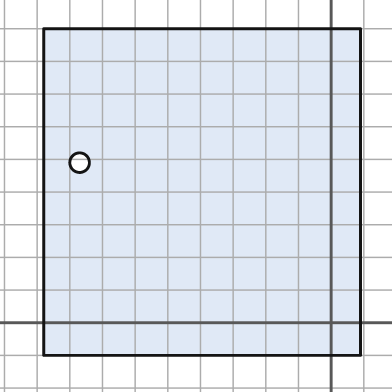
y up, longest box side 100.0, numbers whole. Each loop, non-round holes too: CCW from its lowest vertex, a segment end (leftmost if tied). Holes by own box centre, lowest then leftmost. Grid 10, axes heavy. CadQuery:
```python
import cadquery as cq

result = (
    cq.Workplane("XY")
    .moveTo(-88.0, -10.0)
    .lineTo(9.0, -10.0)
    .lineTo(9.0, 90.0)
    .lineTo(-88.0, 90.0)
    .close()
    .moveTo(-77.0, 49.0)
    .circle(3.0)
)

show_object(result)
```